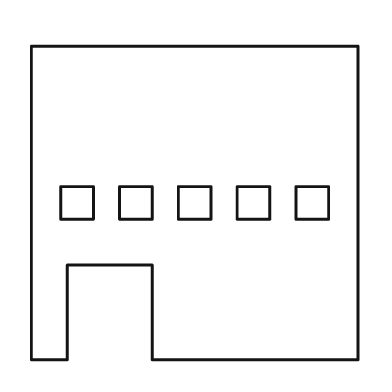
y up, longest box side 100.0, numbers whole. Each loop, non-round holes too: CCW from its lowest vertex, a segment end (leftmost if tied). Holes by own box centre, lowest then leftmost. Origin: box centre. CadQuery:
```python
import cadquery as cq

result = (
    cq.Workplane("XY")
    .moveTo(-50.0, -48.0)
    .lineTo(-39.0, -48.0)
    .lineTo(-39.0, -19.0)
    .lineTo(-13.0, -19.0)
    .lineTo(-13.0, -48.0)
    .lineTo(50.0, -48.0)
    .lineTo(50.0, 48.0)
    .lineTo(-50.0, 48.0)
    .close()
    .moveTo(-41.0, -5.0)
    .lineTo(-31.0, -5.0)
    .lineTo(-31.0, 5.0)
    .lineTo(-41.0, 5.0)
    .close()
    .moveTo(-23.0, -5.0)
    .lineTo(-13.0, -5.0)
    .lineTo(-13.0, 5.0)
    .lineTo(-23.0, 5.0)
    .close()
    .moveTo(-5.0, -5.0)
    .lineTo(5.0, -5.0)
    .lineTo(5.0, 5.0)
    .lineTo(-5.0, 5.0)
    .close()
    .moveTo(13.0, -5.0)
    .lineTo(23.0, -5.0)
    .lineTo(23.0, 5.0)
    .lineTo(13.0, 5.0)
    .close()
    .moveTo(31.0, -5.0)
    .lineTo(41.0, -5.0)
    .lineTo(41.0, 5.0)
    .lineTo(31.0, 5.0)
    .close()
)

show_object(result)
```